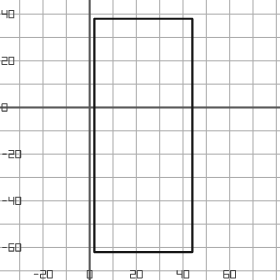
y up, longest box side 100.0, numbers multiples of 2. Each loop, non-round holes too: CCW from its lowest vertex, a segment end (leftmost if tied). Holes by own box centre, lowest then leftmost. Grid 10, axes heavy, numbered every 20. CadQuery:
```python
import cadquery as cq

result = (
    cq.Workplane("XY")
    .moveTo(2.0, -62.0)
    .lineTo(44.0, -62.0)
    .lineTo(44.0, 38.0)
    .lineTo(2.0, 38.0)
    .close()
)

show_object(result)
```